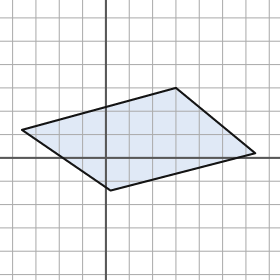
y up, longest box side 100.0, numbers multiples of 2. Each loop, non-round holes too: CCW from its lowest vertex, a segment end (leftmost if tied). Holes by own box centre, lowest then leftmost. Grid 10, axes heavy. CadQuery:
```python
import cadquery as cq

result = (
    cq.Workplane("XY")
    .moveTo(2.0, -14.0)
    .lineTo(64.0, 2.0)
    .lineTo(30.0, 30.0)
    .lineTo(-36.0, 12.0)
    .close()
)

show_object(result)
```